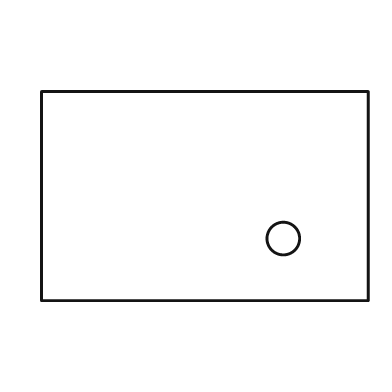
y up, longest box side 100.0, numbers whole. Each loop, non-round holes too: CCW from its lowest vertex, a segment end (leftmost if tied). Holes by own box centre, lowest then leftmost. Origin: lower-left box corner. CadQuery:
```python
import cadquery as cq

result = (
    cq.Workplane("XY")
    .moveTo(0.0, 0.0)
    .lineTo(100.0, 0.0)
    .lineTo(100.0, 64.0)
    .lineTo(0.0, 64.0)
    .close()
    .moveTo(74.0, 19.0)
    .circle(5.0)
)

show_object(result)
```